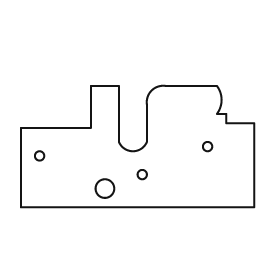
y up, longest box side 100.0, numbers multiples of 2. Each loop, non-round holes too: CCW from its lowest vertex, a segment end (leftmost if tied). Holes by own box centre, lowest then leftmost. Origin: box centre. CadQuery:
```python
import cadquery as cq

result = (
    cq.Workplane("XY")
    .moveTo(-50.0, -26.0)
    .lineTo(50.0, -26.0)
    .lineTo(50.0, 10.0)
    .lineTo(38.0, 10.0)
    .lineTo(38.0, 14.0)
    .lineTo(34.0, 14.0)
    .threePointArc((36.0, 20.0), (34.0, 26.0))
    .lineTo(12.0, 26.0)
    .threePointArc((6.0, 24.0), (4.0, 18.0))
    .lineTo(4.0, 2.0)
    .threePointArc((-2.0, -2.0), (-8.0, 2.0))
    .lineTo(-8.0, 26.0)
    .lineTo(-20.0, 26.0)
    .lineTo(-20.0, 8.0)
    .lineTo(-50.0, 8.0)
    .close()
    .moveTo(-14.0, -18.0)
    .circle(4.0)
    .moveTo(2.0, -12.0)
    .circle(2.0)
    .moveTo(-42.0, -4.0)
    .circle(2.0)
    .moveTo(30.0, 0.0)
    .circle(2.0)
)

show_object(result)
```